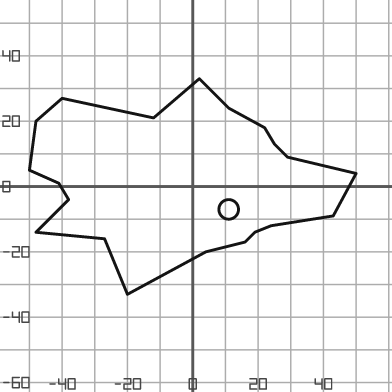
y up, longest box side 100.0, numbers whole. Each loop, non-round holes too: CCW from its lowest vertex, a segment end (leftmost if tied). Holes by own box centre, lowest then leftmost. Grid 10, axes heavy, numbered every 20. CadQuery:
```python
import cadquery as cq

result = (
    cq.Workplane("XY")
    .moveTo(-20.0, -33.0)
    .lineTo(4.0, -20.0)
    .lineTo(16.0, -17.0)
    .lineTo(19.0, -14.0)
    .lineTo(24.0, -12.0)
    .lineTo(43.0, -9.0)
    .lineTo(50.0, 4.0)
    .lineTo(29.0, 9.0)
    .lineTo(25.0, 13.0)
    .lineTo(22.0, 18.0)
    .lineTo(11.0, 24.0)
    .lineTo(2.0, 33.0)
    .lineTo(-12.0, 21.0)
    .lineTo(-40.0, 27.0)
    .lineTo(-48.0, 20.0)
    .lineTo(-50.0, 5.0)
    .lineTo(-41.0, 1.0)
    .lineTo(-38.0, -4.0)
    .lineTo(-48.0, -14.0)
    .lineTo(-27.0, -16.0)
    .close()
    .moveTo(11.0, -7.0)
    .circle(3.0)
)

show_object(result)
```